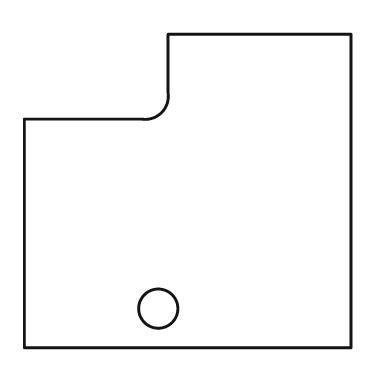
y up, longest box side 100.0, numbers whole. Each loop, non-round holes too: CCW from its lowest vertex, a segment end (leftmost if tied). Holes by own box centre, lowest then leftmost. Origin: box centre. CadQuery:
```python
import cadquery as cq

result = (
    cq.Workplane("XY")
    .moveTo(-50.0, -48.0)
    .lineTo(50.0, -48.0)
    .lineTo(50.0, 48.0)
    .lineTo(-6.0, 48.0)
    .lineTo(-6.0, 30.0)
    .threePointArc((-8.0, 24.0), (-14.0, 22.0))
    .lineTo(-50.0, 22.0)
    .close()
    .moveTo(-9.0, -36.0)
    .circle(6.0)
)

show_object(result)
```